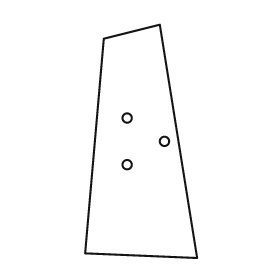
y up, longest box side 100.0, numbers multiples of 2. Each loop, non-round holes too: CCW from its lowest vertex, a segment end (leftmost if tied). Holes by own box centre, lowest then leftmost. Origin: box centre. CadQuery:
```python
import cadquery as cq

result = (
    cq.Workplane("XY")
    .moveTo(24.0, -50.0)
    .lineTo(8.0, 50.0)
    .lineTo(-16.0, 44.0)
    .lineTo(-24.0, -48.0)
    .close()
    .moveTo(-6.0, -10.0)
    .circle(2.0)
    .moveTo(10.0, 0.0)
    .circle(2.0)
    .moveTo(-6.0, 10.0)
    .circle(2.0)
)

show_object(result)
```